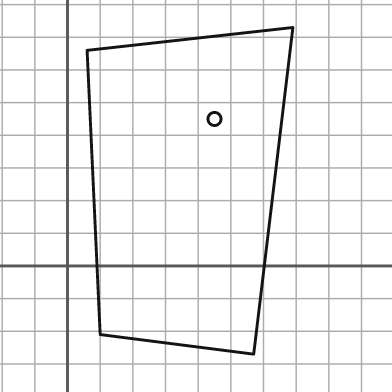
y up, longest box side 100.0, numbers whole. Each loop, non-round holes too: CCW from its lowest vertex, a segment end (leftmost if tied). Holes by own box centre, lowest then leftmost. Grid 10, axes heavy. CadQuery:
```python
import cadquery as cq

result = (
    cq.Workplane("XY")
    .moveTo(57.0, -27.0)
    .lineTo(69.0, 73.0)
    .lineTo(6.0, 66.0)
    .lineTo(10.0, -21.0)
    .close()
    .moveTo(45.0, 45.0)
    .circle(2.0)
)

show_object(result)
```